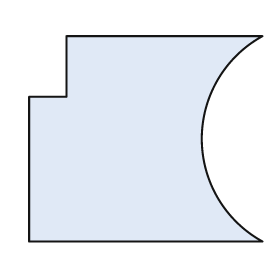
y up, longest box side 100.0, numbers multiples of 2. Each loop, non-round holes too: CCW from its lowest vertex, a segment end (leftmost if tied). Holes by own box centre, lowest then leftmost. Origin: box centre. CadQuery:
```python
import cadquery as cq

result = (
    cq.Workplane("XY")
    .moveTo(-50.0, -44.0)
    .lineTo(50.0, -44.0)
    .threePointArc((24.0, 0.0), (50.0, 44.0))
    .lineTo(-34.0, 44.0)
    .lineTo(-34.0, 18.0)
    .lineTo(-50.0, 18.0)
    .close()
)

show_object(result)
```